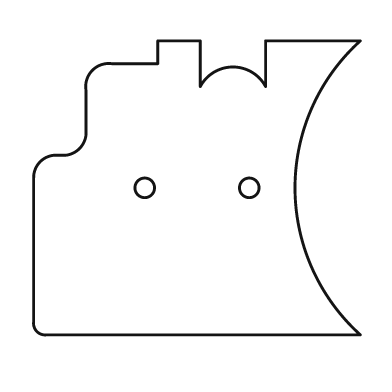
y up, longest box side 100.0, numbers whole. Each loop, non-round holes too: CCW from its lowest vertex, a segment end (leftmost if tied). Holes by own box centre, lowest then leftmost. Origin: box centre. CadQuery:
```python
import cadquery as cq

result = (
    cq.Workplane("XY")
    .moveTo(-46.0, -45.0)
    .lineTo(50.0, -45.0)
    .threePointArc((30.0, 0.0), (50.0, 45.0))
    .lineTo(21.0, 45.0)
    .lineTo(21.0, 31.0)
    .threePointArc((11.0, 37.0), (1.0, 31.0))
    .lineTo(1.0, 45.0)
    .lineTo(-12.0, 45.0)
    .lineTo(-12.0, 38.0)
    .lineTo(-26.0, 38.0)
    .threePointArc((-32.0, 36.0), (-34.0, 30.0))
    .lineTo(-34.0, 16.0)
    .threePointArc((-36.0, 12.0), (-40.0, 10.0))
    .lineTo(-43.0, 10.0)
    .threePointArc((-48.0, 8.0), (-50.0, 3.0))
    .lineTo(-50.0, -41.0)
    .threePointArc((-49.0, -44.0), (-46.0, -45.0))
    .close()
    .moveTo(-16.0, 0.0)
    .circle(3.0)
    .moveTo(16.0, 0.0)
    .circle(3.0)
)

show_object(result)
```